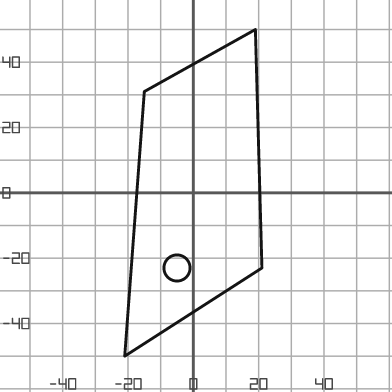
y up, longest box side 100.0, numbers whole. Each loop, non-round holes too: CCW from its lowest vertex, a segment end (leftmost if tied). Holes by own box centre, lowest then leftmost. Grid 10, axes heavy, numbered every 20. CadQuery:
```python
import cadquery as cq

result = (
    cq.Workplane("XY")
    .moveTo(-21.0, -50.0)
    .lineTo(21.0, -23.0)
    .lineTo(19.0, 50.0)
    .lineTo(-15.0, 31.0)
    .close()
    .moveTo(-5.0, -23.0)
    .circle(4.0)
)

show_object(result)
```